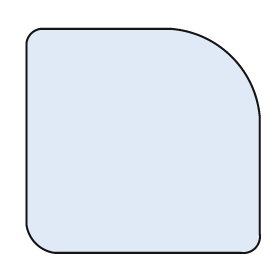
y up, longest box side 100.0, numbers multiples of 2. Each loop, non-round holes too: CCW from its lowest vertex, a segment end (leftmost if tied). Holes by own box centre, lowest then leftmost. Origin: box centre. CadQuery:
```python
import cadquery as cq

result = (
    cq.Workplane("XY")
    .moveTo(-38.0, -48.0)
    .lineTo(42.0, -48.0)
    .threePointArc((48.0, -46.0), (50.0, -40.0))
    .lineTo(50.0, 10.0)
    .threePointArc((38.0, 36.0), (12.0, 48.0))
    .lineTo(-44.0, 48.0)
    .threePointArc((-48.0, 46.0), (-50.0, 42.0))
    .lineTo(-50.0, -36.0)
    .threePointArc((-46.0, -44.0), (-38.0, -48.0))
    .close()
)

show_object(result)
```